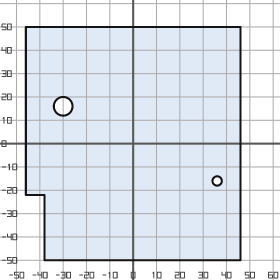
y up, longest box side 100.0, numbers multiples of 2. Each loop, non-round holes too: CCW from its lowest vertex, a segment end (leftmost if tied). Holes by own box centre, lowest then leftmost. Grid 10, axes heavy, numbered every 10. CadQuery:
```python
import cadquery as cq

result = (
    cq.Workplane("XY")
    .moveTo(-38.0, -50.0)
    .lineTo(46.0, -50.0)
    .lineTo(46.0, 50.0)
    .lineTo(-46.0, 50.0)
    .lineTo(-46.0, -22.0)
    .lineTo(-38.0, -22.0)
    .close()
    .moveTo(36.0, -16.0)
    .circle(2.0)
    .moveTo(-30.0, 16.0)
    .circle(4.0)
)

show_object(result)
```